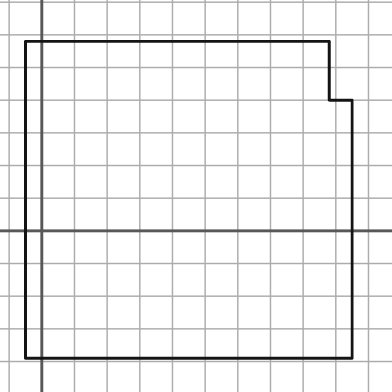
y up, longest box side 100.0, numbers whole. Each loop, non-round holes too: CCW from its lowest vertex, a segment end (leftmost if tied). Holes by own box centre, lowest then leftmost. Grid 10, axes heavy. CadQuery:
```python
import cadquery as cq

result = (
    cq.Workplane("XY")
    .moveTo(-5.0, -39.0)
    .lineTo(95.0, -39.0)
    .lineTo(95.0, 40.0)
    .lineTo(88.0, 40.0)
    .lineTo(88.0, 58.0)
    .lineTo(-5.0, 58.0)
    .close()
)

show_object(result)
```